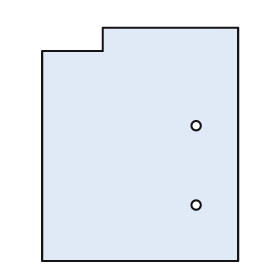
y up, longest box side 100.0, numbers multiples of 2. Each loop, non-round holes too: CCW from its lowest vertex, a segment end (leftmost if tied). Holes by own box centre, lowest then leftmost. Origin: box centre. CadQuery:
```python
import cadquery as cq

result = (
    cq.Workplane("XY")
    .moveTo(-42.0, -50.0)
    .lineTo(42.0, -50.0)
    .lineTo(42.0, 50.0)
    .lineTo(-16.0, 50.0)
    .lineTo(-16.0, 40.0)
    .lineTo(-42.0, 40.0)
    .close()
    .moveTo(24.0, -26.0)
    .circle(2.0)
    .moveTo(24.0, 8.0)
    .circle(2.0)
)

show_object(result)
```